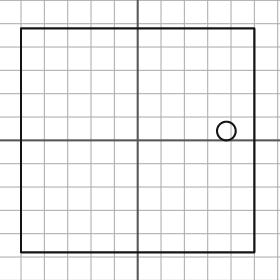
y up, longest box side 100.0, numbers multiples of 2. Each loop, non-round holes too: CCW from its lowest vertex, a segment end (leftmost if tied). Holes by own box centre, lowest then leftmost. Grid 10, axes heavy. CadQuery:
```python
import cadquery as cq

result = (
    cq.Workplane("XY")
    .moveTo(-50.0, -48.0)
    .lineTo(50.0, -48.0)
    .lineTo(50.0, 48.0)
    .lineTo(-50.0, 48.0)
    .close()
    .moveTo(38.0, 4.0)
    .circle(4.0)
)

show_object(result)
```